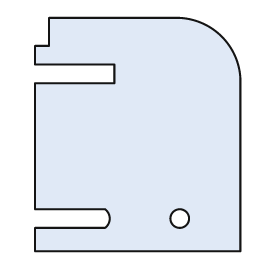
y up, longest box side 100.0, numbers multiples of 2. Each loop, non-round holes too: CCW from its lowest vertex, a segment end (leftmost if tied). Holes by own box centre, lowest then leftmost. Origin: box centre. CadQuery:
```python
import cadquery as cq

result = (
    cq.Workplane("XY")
    .moveTo(-44.0, -50.0)
    .lineTo(44.0, -50.0)
    .lineTo(44.0, 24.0)
    .threePointArc((36.0, 42.0), (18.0, 50.0))
    .lineTo(-38.0, 50.0)
    .lineTo(-38.0, 38.0)
    .lineTo(-44.0, 38.0)
    .lineTo(-44.0, 30.0)
    .lineTo(-10.0, 30.0)
    .lineTo(-10.0, 22.0)
    .lineTo(-44.0, 22.0)
    .lineTo(-44.0, -32.0)
    .lineTo(-14.0, -32.0)
    .threePointArc((-12.0, -36.0), (-14.0, -40.0))
    .lineTo(-44.0, -40.0)
    .close()
    .moveTo(18.0, -36.0)
    .circle(4.0)
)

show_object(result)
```